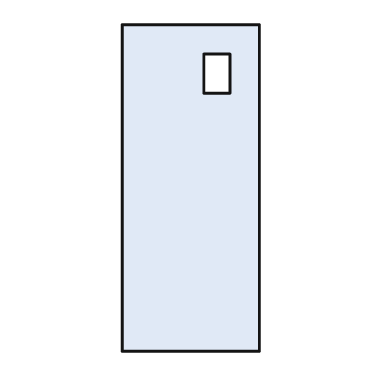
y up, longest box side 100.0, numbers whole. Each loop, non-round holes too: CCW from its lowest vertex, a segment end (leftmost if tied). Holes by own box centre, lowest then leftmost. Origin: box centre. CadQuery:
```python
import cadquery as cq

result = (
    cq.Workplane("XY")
    .moveTo(-21.0, -50.0)
    .lineTo(21.0, -50.0)
    .lineTo(21.0, 50.0)
    .lineTo(-21.0, 50.0)
    .close()
    .moveTo(4.0, 29.0)
    .lineTo(12.0, 29.0)
    .lineTo(12.0, 41.0)
    .lineTo(4.0, 41.0)
    .close()
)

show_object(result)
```